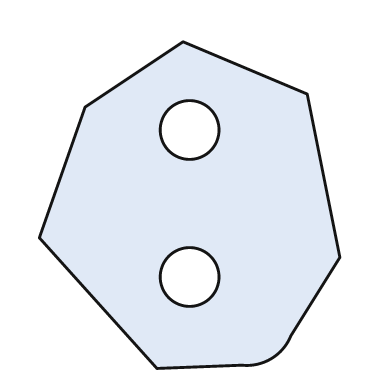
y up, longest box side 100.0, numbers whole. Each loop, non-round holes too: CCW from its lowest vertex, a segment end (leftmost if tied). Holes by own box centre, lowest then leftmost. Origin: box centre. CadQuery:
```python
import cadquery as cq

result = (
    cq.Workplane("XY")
    .moveTo(-10.0, -50.0)
    .lineTo(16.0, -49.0)
    .threePointArc((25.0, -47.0), (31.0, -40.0))
    .lineTo(46.0, -16.0)
    .lineTo(36.0, 34.0)
    .lineTo(-2.0, 50.0)
    .lineTo(-32.0, 30.0)
    .lineTo(-46.0, -10.0)
    .close()
    .moveTo(0.0, -22.0)
    .circle(9.0)
    .moveTo(0.0, 23.0)
    .circle(9.0)
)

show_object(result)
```